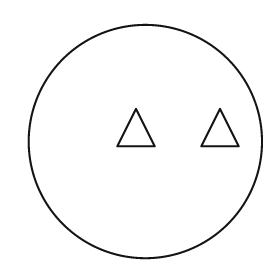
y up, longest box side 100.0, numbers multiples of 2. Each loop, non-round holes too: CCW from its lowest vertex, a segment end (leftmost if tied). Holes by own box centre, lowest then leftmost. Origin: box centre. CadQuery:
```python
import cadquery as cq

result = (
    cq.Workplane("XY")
    .moveTo(0.0, 0.0)
    .circle(50.0)
    .moveTo(-12.0, -2.0)
    .lineTo(4.0, -2.0)
    .lineTo(-4.0, 14.0)
    .close()
    .moveTo(24.0, -2.0)
    .lineTo(40.0, -2.0)
    .lineTo(32.0, 14.0)
    .close()
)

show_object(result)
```